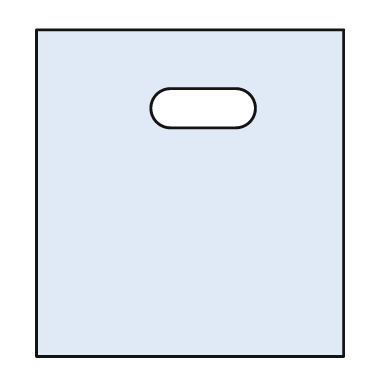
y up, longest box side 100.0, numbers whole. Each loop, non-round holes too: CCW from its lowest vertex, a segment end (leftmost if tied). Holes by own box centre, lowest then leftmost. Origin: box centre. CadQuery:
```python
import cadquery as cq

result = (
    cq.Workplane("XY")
    .moveTo(-47.0, -50.0)
    .lineTo(47.0, -50.0)
    .lineTo(47.0, 50.0)
    .lineTo(-47.0, 50.0)
    .close()
    .moveTo(-6.0, 20.0)
    .lineTo(14.0, 20.0)
    .threePointArc((20.0, 26.0), (14.0, 32.0))
    .lineTo(-6.0, 32.0)
    .threePointArc((-12.0, 26.0), (-6.0, 20.0))
    .close()
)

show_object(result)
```